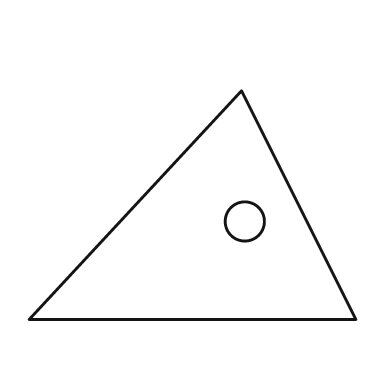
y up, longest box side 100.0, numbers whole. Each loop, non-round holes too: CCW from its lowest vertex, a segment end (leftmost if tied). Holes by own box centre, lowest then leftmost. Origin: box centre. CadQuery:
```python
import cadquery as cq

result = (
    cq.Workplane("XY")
    .moveTo(-50.0, -35.0)
    .lineTo(50.0, -35.0)
    .lineTo(15.0, 35.0)
    .close()
    .moveTo(16.0, -5.0)
    .circle(6.0)
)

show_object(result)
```